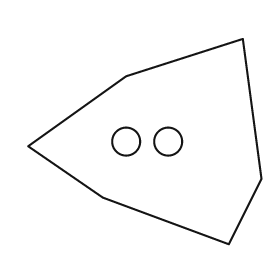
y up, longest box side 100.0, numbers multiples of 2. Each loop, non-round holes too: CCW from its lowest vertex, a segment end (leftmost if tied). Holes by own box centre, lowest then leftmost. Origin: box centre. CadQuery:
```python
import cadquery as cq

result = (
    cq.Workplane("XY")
    .moveTo(36.0, -44.0)
    .lineTo(50.0, -16.0)
    .lineTo(42.0, 44.0)
    .lineTo(-8.0, 28.0)
    .lineTo(-50.0, -2.0)
    .lineTo(-18.0, -24.0)
    .close()
    .moveTo(-8.0, 0.0)
    .circle(6.0)
    .moveTo(10.0, 0.0)
    .circle(6.0)
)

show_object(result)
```